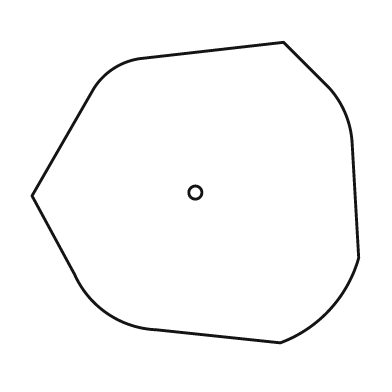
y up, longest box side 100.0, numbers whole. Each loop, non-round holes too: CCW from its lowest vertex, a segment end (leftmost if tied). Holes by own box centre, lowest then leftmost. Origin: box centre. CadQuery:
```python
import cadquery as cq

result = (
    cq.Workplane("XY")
    .moveTo(26.0, -46.0)
    .threePointArc((41.0, -36.0), (50.0, -20.0))
    .lineTo(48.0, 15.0)
    .threePointArc((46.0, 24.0), (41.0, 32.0))
    .lineTo(27.0, 46.0)
    .lineTo(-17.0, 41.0)
    .threePointArc((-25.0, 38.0), (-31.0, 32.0))
    .lineTo(-50.0, -1.0)
    .lineTo(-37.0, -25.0)
    .threePointArc((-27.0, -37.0), (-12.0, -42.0))
    .close()
    .moveTo(0.0, 0.0)
    .circle(2.0)
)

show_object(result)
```